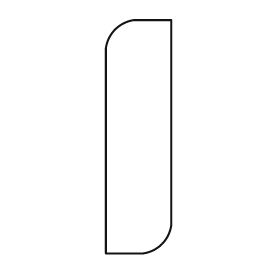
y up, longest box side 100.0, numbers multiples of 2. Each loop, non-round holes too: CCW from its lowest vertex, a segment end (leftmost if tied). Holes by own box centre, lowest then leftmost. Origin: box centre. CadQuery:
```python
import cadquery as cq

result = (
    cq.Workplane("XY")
    .moveTo(-14.0, -50.0)
    .lineTo(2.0, -50.0)
    .threePointArc((10.0, -46.0), (14.0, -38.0))
    .lineTo(14.0, 50.0)
    .lineTo(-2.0, 50.0)
    .threePointArc((-10.0, 46.0), (-14.0, 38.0))
    .close()
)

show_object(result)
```